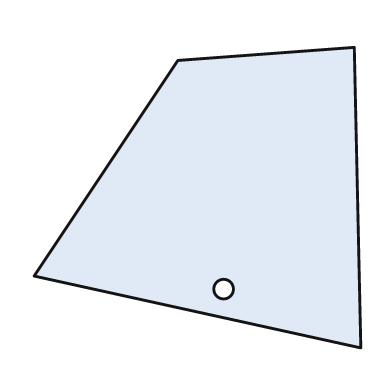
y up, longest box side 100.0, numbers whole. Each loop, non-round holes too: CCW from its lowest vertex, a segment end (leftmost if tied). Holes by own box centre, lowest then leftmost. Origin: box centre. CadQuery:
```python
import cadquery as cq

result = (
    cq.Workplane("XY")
    .moveTo(50.0, -46.0)
    .lineTo(48.0, 46.0)
    .lineTo(-6.0, 42.0)
    .lineTo(-50.0, -24.0)
    .close()
    .moveTo(8.0, -28.0)
    .circle(3.0)
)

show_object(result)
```